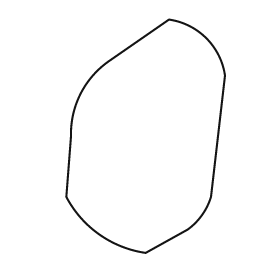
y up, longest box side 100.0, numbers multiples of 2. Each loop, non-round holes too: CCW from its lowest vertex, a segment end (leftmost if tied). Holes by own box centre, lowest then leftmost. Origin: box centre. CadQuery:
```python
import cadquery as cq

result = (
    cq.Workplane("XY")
    .moveTo(0.0, -50.0)
    .lineTo(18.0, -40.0)
    .threePointArc((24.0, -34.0), (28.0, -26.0))
    .lineTo(34.0, 26.0)
    .threePointArc((26.0, 42.0), (10.0, 50.0))
    .lineTo(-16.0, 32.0)
    .threePointArc((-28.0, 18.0), (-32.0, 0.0))
    .lineTo(-34.0, -26.0)
    .threePointArc((-20.0, -42.0), (0.0, -50.0))
    .close()
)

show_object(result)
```